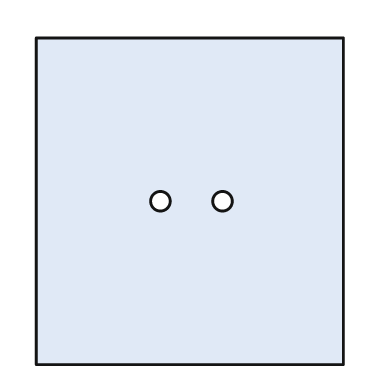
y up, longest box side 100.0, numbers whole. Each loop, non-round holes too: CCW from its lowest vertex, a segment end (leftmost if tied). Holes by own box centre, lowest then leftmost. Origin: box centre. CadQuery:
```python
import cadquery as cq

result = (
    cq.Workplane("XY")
    .moveTo(-47.0, -50.0)
    .lineTo(47.0, -50.0)
    .lineTo(47.0, 50.0)
    .lineTo(-47.0, 50.0)
    .close()
    .moveTo(-9.0, 0.0)
    .circle(3.0)
    .moveTo(10.0, 0.0)
    .circle(3.0)
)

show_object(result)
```